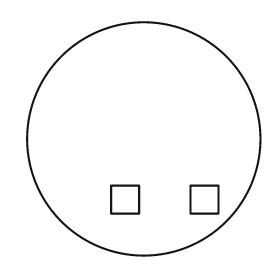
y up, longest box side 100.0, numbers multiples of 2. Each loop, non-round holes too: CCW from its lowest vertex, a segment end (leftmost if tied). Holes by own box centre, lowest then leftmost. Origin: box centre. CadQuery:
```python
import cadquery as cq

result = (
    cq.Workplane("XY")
    .moveTo(0.0, 0.0)
    .circle(50.0)
    .moveTo(-14.0, -32.0)
    .lineTo(-2.0, -32.0)
    .lineTo(-2.0, -20.0)
    .lineTo(-14.0, -20.0)
    .close()
    .moveTo(20.0, -32.0)
    .lineTo(32.0, -32.0)
    .lineTo(32.0, -20.0)
    .lineTo(20.0, -20.0)
    .close()
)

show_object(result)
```